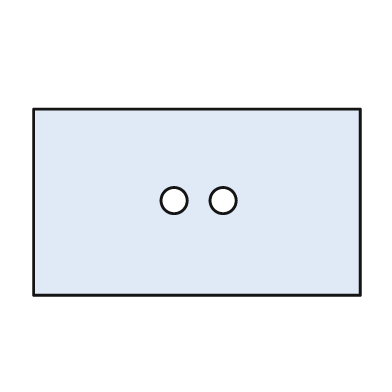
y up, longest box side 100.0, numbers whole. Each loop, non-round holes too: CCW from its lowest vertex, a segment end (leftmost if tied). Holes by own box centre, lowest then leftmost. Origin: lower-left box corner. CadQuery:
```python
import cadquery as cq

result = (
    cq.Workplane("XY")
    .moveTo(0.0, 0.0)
    .lineTo(100.0, 0.0)
    .lineTo(100.0, 57.0)
    .lineTo(0.0, 57.0)
    .close()
    .moveTo(43.0, 29.0)
    .circle(4.0)
    .moveTo(58.0, 29.0)
    .circle(4.0)
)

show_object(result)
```